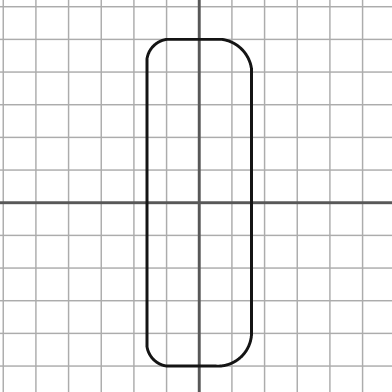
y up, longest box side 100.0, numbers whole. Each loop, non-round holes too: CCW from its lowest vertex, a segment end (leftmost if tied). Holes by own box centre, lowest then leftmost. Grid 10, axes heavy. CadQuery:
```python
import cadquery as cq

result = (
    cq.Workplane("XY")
    .moveTo(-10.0, -50.0)
    .lineTo(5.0, -50.0)
    .threePointArc((13.0, -47.0), (16.0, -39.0))
    .lineTo(16.0, 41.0)
    .threePointArc((13.0, 47.0), (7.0, 50.0))
    .lineTo(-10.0, 50.0)
    .threePointArc((-14.0, 48.0), (-16.0, 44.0))
    .lineTo(-16.0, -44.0)
    .threePointArc((-14.0, -48.0), (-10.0, -50.0))
    .close()
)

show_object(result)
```